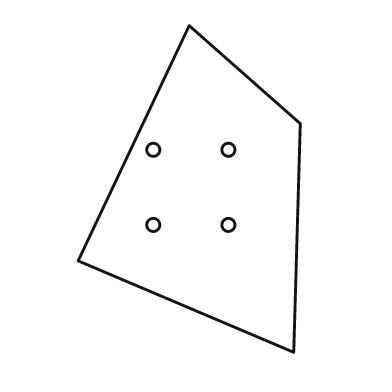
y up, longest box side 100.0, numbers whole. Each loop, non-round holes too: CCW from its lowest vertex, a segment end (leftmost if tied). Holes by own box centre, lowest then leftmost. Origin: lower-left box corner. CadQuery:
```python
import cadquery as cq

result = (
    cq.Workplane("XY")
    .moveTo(66.0, 0.0)
    .lineTo(68.0, 70.0)
    .lineTo(34.0, 100.0)
    .lineTo(0.0, 28.0)
    .close()
    .moveTo(23.0, 39.0)
    .circle(2.0)
    .moveTo(46.0, 39.0)
    .circle(2.0)
    .moveTo(23.0, 62.0)
    .circle(2.0)
    .moveTo(46.0, 62.0)
    .circle(2.0)
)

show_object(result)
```